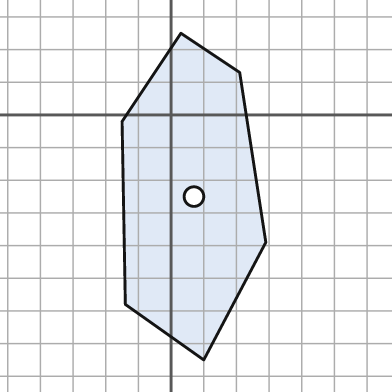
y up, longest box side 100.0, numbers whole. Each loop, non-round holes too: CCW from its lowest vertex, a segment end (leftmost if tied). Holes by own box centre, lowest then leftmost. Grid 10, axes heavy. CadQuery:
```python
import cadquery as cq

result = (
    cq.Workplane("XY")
    .moveTo(10.0, -75.0)
    .lineTo(29.0, -39.0)
    .lineTo(21.0, 13.0)
    .lineTo(3.0, 25.0)
    .lineTo(-15.0, -2.0)
    .lineTo(-14.0, -58.0)
    .close()
    .moveTo(7.0, -25.0)
    .circle(3.0)
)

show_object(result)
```